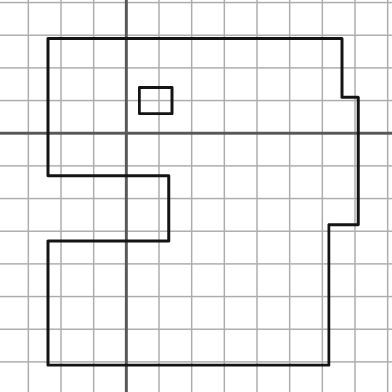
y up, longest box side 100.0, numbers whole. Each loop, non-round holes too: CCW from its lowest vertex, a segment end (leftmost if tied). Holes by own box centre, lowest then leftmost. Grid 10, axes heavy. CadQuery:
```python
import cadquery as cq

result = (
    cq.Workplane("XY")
    .moveTo(-24.0, -71.0)
    .lineTo(62.0, -71.0)
    .lineTo(62.0, -28.0)
    .lineTo(71.0, -28.0)
    .lineTo(71.0, 11.0)
    .lineTo(66.0, 11.0)
    .lineTo(66.0, 29.0)
    .lineTo(-24.0, 29.0)
    .lineTo(-24.0, -13.0)
    .lineTo(13.0, -13.0)
    .lineTo(13.0, -33.0)
    .lineTo(-24.0, -33.0)
    .close()
    .moveTo(4.0, 6.0)
    .lineTo(14.0, 6.0)
    .lineTo(14.0, 14.0)
    .lineTo(4.0, 14.0)
    .close()
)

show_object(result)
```